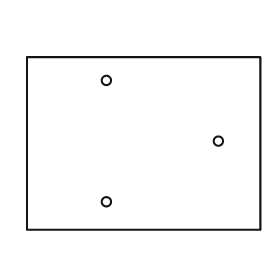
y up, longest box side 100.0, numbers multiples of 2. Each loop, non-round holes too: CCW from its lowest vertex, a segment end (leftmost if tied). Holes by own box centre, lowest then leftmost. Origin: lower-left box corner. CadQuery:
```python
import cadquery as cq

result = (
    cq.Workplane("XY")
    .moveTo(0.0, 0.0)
    .lineTo(100.0, 0.0)
    .lineTo(100.0, 74.0)
    .lineTo(0.0, 74.0)
    .close()
    .moveTo(34.0, 12.0)
    .circle(2.0)
    .moveTo(82.0, 38.0)
    .circle(2.0)
    .moveTo(34.0, 64.0)
    .circle(2.0)
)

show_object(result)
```